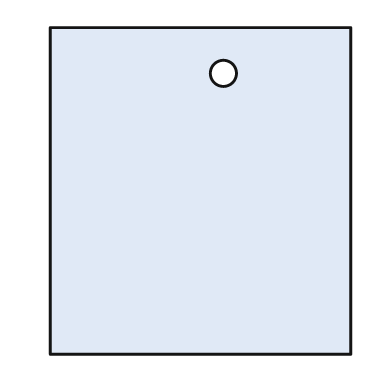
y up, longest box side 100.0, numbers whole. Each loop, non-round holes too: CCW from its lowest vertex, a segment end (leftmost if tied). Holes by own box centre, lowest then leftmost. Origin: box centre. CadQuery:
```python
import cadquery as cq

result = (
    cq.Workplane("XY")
    .moveTo(-46.0, -50.0)
    .lineTo(46.0, -50.0)
    .lineTo(46.0, 50.0)
    .lineTo(-46.0, 50.0)
    .close()
    .moveTo(7.0, 36.0)
    .circle(4.0)
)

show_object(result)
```